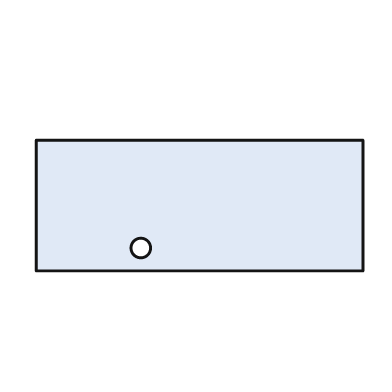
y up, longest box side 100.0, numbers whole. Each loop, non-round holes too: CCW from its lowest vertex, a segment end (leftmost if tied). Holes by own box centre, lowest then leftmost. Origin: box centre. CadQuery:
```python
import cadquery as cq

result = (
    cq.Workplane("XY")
    .moveTo(-50.0, -20.0)
    .lineTo(50.0, -20.0)
    .lineTo(50.0, 20.0)
    .lineTo(-50.0, 20.0)
    .close()
    .moveTo(-18.0, -13.0)
    .circle(3.0)
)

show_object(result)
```